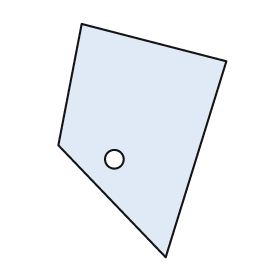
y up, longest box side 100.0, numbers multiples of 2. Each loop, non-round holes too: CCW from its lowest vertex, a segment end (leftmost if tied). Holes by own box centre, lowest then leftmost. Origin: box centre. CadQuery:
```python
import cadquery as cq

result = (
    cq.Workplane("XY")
    .moveTo(10.0, -50.0)
    .lineTo(36.0, 34.0)
    .lineTo(-26.0, 50.0)
    .lineTo(-36.0, -2.0)
    .close()
    .moveTo(-12.0, -8.0)
    .circle(4.0)
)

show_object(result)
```